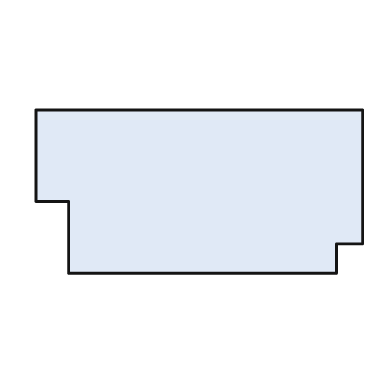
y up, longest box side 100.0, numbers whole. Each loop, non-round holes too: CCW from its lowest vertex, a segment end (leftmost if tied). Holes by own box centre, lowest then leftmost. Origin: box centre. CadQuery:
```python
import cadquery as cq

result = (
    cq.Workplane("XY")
    .moveTo(-40.0, -25.0)
    .lineTo(42.0, -25.0)
    .lineTo(42.0, -16.0)
    .lineTo(50.0, -16.0)
    .lineTo(50.0, 25.0)
    .lineTo(-50.0, 25.0)
    .lineTo(-50.0, -3.0)
    .lineTo(-40.0, -3.0)
    .close()
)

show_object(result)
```